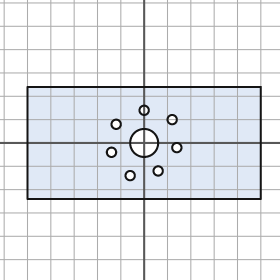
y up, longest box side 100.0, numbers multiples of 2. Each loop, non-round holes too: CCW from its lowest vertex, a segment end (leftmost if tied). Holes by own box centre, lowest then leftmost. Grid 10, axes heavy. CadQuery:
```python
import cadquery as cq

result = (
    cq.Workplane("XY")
    .moveTo(-50.0, -24.0)
    .lineTo(50.0, -24.0)
    .lineTo(50.0, 24.0)
    .lineTo(-50.0, 24.0)
    .close()
    .moveTo(-6.0, -14.0)
    .circle(2.0)
    .moveTo(6.0, -12.0)
    .circle(2.0)
    .moveTo(-14.0, -4.0)
    .circle(2.0)
    .moveTo(14.0, -2.0)
    .circle(2.0)
    .moveTo(0.0, 0.0)
    .circle(6.0)
    .moveTo(-12.0, 8.0)
    .circle(2.0)
    .moveTo(12.0, 10.0)
    .circle(2.0)
    .moveTo(0.0, 14.0)
    .circle(2.0)
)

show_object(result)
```